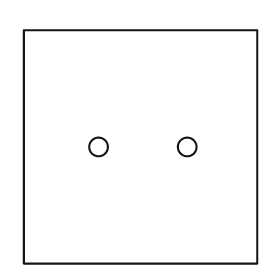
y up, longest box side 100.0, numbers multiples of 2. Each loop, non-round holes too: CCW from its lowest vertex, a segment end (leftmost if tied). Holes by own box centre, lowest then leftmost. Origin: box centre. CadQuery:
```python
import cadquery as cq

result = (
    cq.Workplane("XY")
    .moveTo(-50.0, -50.0)
    .lineTo(50.0, -50.0)
    .lineTo(50.0, 50.0)
    .lineTo(-50.0, 50.0)
    .close()
    .moveTo(-18.0, 0.0)
    .circle(4.0)
    .moveTo(20.0, 0.0)
    .circle(4.0)
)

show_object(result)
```